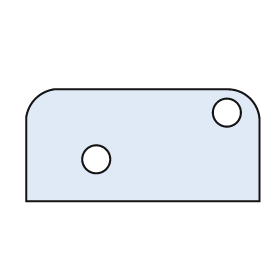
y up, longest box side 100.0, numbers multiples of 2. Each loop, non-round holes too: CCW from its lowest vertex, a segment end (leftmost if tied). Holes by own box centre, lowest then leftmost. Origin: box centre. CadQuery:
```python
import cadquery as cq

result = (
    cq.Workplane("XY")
    .moveTo(-50.0, -24.0)
    .lineTo(50.0, -24.0)
    .lineTo(50.0, 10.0)
    .threePointArc((46.0, 20.0), (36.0, 24.0))
    .lineTo(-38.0, 24.0)
    .threePointArc((-46.0, 20.0), (-50.0, 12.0))
    .close()
    .moveTo(-20.0, -6.0)
    .circle(6.0)
    .moveTo(36.0, 14.0)
    .circle(6.0)
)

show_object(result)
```